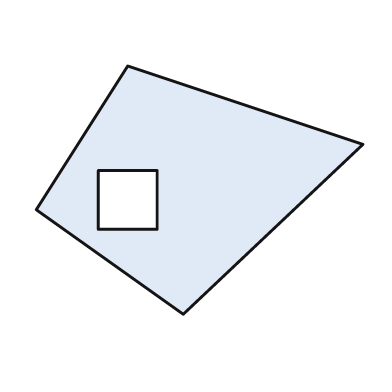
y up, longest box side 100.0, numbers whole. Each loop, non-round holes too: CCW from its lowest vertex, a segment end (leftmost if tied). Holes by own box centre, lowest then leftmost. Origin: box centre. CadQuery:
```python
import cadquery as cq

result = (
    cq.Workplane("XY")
    .moveTo(-5.0, -38.0)
    .lineTo(50.0, 14.0)
    .lineTo(-22.0, 38.0)
    .lineTo(-50.0, -6.0)
    .close()
    .moveTo(-31.0, -12.0)
    .lineTo(-13.0, -12.0)
    .lineTo(-13.0, 6.0)
    .lineTo(-31.0, 6.0)
    .close()
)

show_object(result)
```